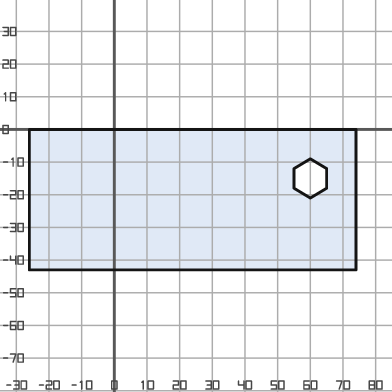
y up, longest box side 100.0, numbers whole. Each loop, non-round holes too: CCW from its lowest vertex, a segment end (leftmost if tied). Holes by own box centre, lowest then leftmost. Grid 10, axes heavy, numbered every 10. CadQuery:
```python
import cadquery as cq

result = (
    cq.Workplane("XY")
    .moveTo(-26.0, -43.0)
    .lineTo(74.0, -43.0)
    .lineTo(74.0, 0.0)
    .lineTo(-26.0, 0.0)
    .close()
    .moveTo(60.0, -21.0)
    .lineTo(65.0, -18.0)
    .lineTo(65.0, -12.0)
    .lineTo(60.0, -9.0)
    .lineTo(55.0, -12.0)
    .lineTo(55.0, -18.0)
    .close()
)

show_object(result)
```